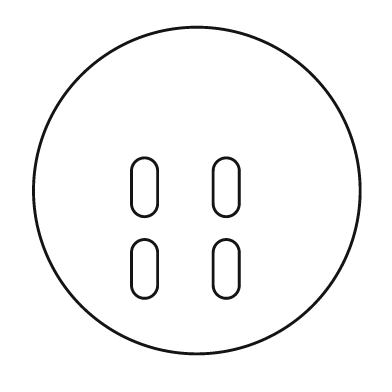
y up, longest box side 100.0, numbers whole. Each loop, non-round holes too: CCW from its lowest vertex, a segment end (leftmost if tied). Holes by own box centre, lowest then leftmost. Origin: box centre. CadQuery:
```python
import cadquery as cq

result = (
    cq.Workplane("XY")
    .moveTo(0.0, 0.0)
    .circle(50.0)
    .moveTo(-20.0, -29.0)
    .threePointArc((-16.0, -33.0), (-12.0, -29.0))
    .lineTo(-12.0, -19.0)
    .threePointArc((-16.0, -15.0), (-20.0, -19.0))
    .close()
    .moveTo(5.0, -29.0)
    .threePointArc((9.0, -33.0), (13.0, -29.0))
    .lineTo(13.0, -19.0)
    .threePointArc((9.0, -15.0), (5.0, -19.0))
    .close()
    .moveTo(-20.0, -4.0)
    .threePointArc((-16.0, -8.0), (-12.0, -4.0))
    .lineTo(-12.0, 6.0)
    .threePointArc((-16.0, 10.0), (-20.0, 6.0))
    .close()
    .moveTo(5.0, -4.0)
    .threePointArc((9.0, -8.0), (13.0, -4.0))
    .lineTo(13.0, 6.0)
    .threePointArc((9.0, 10.0), (5.0, 6.0))
    .close()
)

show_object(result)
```